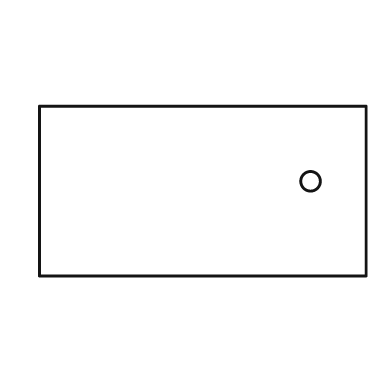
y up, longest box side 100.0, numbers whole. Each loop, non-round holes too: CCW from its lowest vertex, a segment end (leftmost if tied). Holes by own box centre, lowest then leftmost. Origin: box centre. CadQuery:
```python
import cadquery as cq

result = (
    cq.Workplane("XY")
    .moveTo(-50.0, -26.0)
    .lineTo(50.0, -26.0)
    .lineTo(50.0, 26.0)
    .lineTo(-50.0, 26.0)
    .close()
    .moveTo(33.0, 3.0)
    .circle(3.0)
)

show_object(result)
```